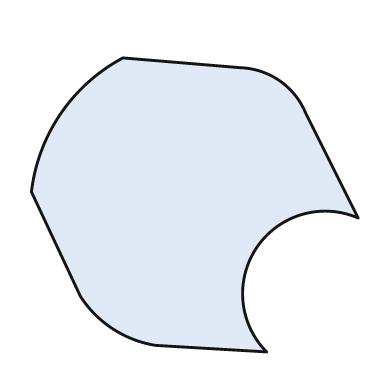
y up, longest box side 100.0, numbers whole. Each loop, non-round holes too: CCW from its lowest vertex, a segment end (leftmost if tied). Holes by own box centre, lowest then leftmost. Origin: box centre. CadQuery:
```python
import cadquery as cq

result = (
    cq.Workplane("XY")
    .moveTo(22.0, -45.0)
    .threePointArc((19.0, -13.0), (50.0, -4.0))
    .lineTo(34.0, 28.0)
    .threePointArc((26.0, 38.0), (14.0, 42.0))
    .lineTo(-22.0, 45.0)
    .threePointArc((-41.0, 28.0), (-50.0, 4.0))
    .lineTo(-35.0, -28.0)
    .threePointArc((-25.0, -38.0), (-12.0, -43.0))
    .close()
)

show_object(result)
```